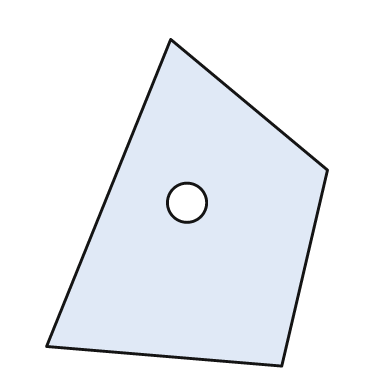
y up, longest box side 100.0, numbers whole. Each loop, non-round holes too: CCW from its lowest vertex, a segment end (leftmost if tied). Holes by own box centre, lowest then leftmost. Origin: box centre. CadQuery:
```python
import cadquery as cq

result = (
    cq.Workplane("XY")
    .moveTo(29.0, -50.0)
    .lineTo(43.0, 10.0)
    .lineTo(-5.0, 50.0)
    .lineTo(-43.0, -44.0)
    .close()
    .moveTo(0.0, 0.0)
    .circle(6.0)
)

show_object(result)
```